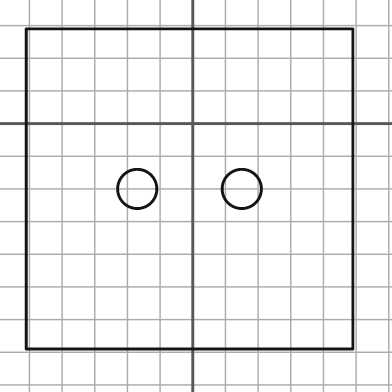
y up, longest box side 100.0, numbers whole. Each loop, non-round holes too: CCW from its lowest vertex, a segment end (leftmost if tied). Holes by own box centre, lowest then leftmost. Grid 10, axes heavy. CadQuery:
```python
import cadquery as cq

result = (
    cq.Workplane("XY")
    .moveTo(-51.0, -69.0)
    .lineTo(49.0, -69.0)
    .lineTo(49.0, 29.0)
    .lineTo(-51.0, 29.0)
    .close()
    .moveTo(-17.0, -20.0)
    .circle(6.0)
    .moveTo(15.0, -20.0)
    .circle(6.0)
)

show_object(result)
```